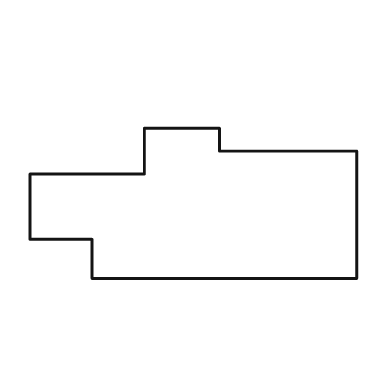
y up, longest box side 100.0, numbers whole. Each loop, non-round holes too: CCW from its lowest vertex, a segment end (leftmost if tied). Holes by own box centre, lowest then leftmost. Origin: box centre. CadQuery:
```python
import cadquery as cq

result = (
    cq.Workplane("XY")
    .moveTo(-31.0, -23.0)
    .lineTo(50.0, -23.0)
    .lineTo(50.0, 16.0)
    .lineTo(8.0, 16.0)
    .lineTo(8.0, 23.0)
    .lineTo(-15.0, 23.0)
    .lineTo(-15.0, 9.0)
    .lineTo(-50.0, 9.0)
    .lineTo(-50.0, -11.0)
    .lineTo(-31.0, -11.0)
    .close()
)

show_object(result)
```